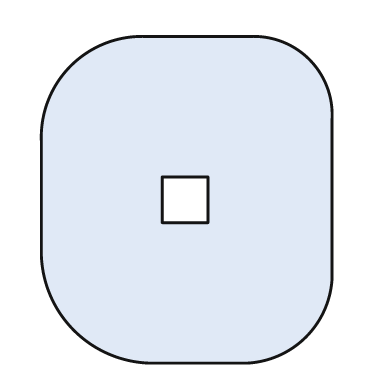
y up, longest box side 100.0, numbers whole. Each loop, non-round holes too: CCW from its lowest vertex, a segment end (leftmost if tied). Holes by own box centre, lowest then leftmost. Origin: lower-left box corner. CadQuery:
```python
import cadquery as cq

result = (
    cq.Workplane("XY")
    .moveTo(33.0, 0.0)
    .lineTo(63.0, 0.0)
    .threePointArc((81.0, 8.0), (89.0, 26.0))
    .lineTo(89.0, 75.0)
    .threePointArc((82.0, 93.0), (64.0, 100.0))
    .lineTo(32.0, 100.0)
    .threePointArc((9.0, 91.0), (0.0, 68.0))
    .lineTo(0.0, 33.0)
    .threePointArc((10.0, 10.0), (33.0, 0.0))
    .close()
    .moveTo(37.0, 43.0)
    .lineTo(51.0, 43.0)
    .lineTo(51.0, 57.0)
    .lineTo(37.0, 57.0)
    .close()
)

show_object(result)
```